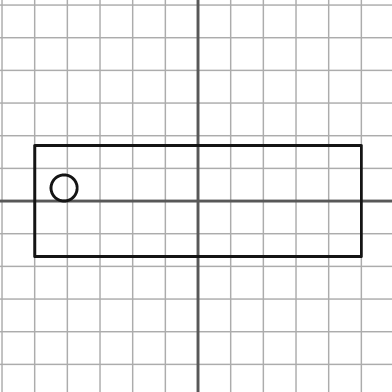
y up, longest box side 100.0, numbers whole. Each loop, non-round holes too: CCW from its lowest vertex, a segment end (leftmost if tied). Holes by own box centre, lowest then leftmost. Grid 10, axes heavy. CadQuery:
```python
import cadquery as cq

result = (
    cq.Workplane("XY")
    .moveTo(-50.0, -17.0)
    .lineTo(50.0, -17.0)
    .lineTo(50.0, 17.0)
    .lineTo(-50.0, 17.0)
    .close()
    .moveTo(-41.0, 4.0)
    .circle(4.0)
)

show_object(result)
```